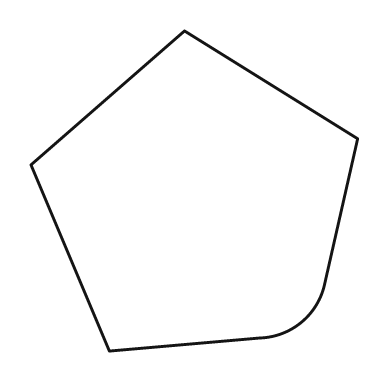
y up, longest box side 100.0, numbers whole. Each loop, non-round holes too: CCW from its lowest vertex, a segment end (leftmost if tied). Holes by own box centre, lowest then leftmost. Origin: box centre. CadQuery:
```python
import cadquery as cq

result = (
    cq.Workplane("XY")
    .moveTo(-26.0, -49.0)
    .lineTo(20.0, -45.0)
    .threePointArc((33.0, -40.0), (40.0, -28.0))
    .lineTo(50.0, 16.0)
    .lineTo(-3.0, 49.0)
    .lineTo(-50.0, 8.0)
    .close()
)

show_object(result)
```